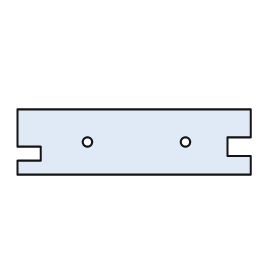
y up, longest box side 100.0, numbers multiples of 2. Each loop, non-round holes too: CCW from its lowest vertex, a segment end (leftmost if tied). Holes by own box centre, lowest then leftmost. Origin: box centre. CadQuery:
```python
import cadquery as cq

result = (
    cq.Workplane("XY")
    .moveTo(-50.0, -14.0)
    .lineTo(50.0, -14.0)
    .lineTo(50.0, -6.0)
    .lineTo(40.0, -6.0)
    .lineTo(40.0, 2.0)
    .lineTo(50.0, 2.0)
    .lineTo(50.0, 14.0)
    .lineTo(-50.0, 14.0)
    .lineTo(-50.0, -2.0)
    .lineTo(-40.0, -2.0)
    .lineTo(-40.0, -8.0)
    .lineTo(-50.0, -8.0)
    .close()
    .moveTo(-20.0, 0.0)
    .circle(2.0)
    .moveTo(22.0, 0.0)
    .circle(2.0)
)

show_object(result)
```